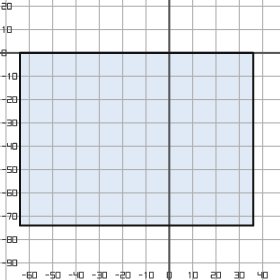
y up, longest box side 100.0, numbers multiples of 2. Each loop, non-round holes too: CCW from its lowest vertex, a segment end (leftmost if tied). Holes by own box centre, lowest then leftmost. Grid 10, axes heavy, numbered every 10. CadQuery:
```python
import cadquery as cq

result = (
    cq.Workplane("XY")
    .moveTo(-64.0, -74.0)
    .lineTo(36.0, -74.0)
    .lineTo(36.0, 0.0)
    .lineTo(-64.0, 0.0)
    .close()
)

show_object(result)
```